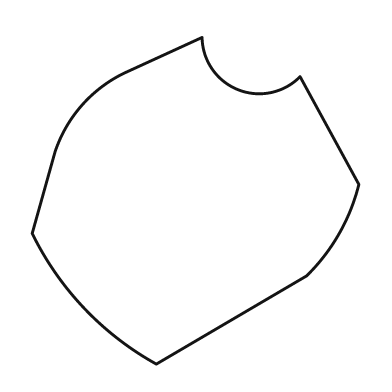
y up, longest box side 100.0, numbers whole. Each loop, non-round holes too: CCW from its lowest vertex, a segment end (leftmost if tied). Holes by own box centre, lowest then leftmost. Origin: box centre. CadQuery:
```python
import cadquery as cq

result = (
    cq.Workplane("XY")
    .moveTo(-12.0, -50.0)
    .lineTo(34.0, -23.0)
    .threePointArc((44.0, -10.0), (50.0, 5.0))
    .lineTo(32.0, 38.0)
    .threePointArc((13.0, 34.0), (2.0, 50.0))
    .lineTo(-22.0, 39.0)
    .threePointArc((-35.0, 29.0), (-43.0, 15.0))
    .lineTo(-50.0, -10.0)
    .threePointArc((-34.0, -33.0), (-12.0, -50.0))
    .close()
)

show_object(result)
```